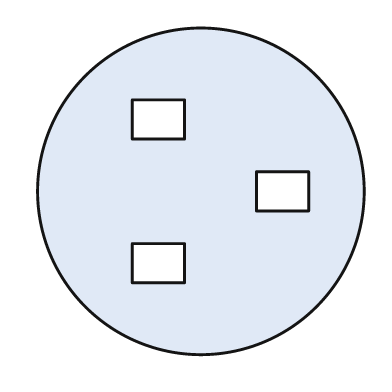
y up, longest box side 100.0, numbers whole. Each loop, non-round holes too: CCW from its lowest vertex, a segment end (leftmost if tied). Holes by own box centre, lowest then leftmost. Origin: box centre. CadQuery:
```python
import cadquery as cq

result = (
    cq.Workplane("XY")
    .moveTo(0.0, 0.0)
    .circle(50.0)
    .moveTo(-21.0, -28.0)
    .lineTo(-5.0, -28.0)
    .lineTo(-5.0, -16.0)
    .lineTo(-21.0, -16.0)
    .close()
    .moveTo(17.0, -6.0)
    .lineTo(33.0, -6.0)
    .lineTo(33.0, 6.0)
    .lineTo(17.0, 6.0)
    .close()
    .moveTo(-21.0, 16.0)
    .lineTo(-5.0, 16.0)
    .lineTo(-5.0, 28.0)
    .lineTo(-21.0, 28.0)
    .close()
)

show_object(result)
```